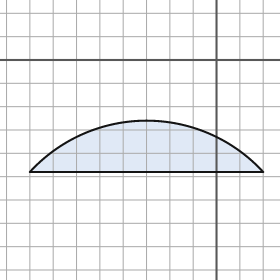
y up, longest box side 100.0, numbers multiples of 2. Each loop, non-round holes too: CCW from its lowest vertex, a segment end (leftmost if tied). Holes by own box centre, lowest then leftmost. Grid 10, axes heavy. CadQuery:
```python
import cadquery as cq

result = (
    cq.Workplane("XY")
    .moveTo(-80.0, -48.0)
    .lineTo(20.0, -48.0)
    .threePointArc((-30.0, -26.0), (-80.0, -48.0))
    .close()
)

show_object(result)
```